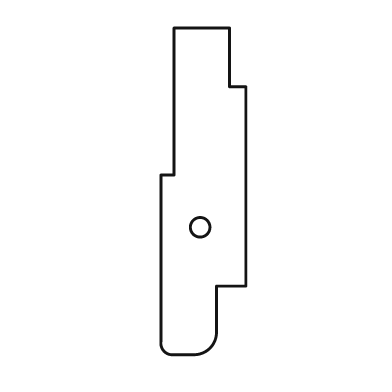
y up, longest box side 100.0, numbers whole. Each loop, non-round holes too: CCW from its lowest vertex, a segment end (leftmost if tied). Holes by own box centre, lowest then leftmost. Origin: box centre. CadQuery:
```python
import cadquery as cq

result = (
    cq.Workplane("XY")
    .moveTo(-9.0, -50.0)
    .lineTo(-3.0, -50.0)
    .threePointArc((2.0, -48.0), (4.0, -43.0))
    .lineTo(4.0, -29.0)
    .lineTo(13.0, -29.0)
    .lineTo(13.0, 32.0)
    .lineTo(8.0, 32.0)
    .lineTo(8.0, 50.0)
    .lineTo(-9.0, 50.0)
    .lineTo(-9.0, 5.0)
    .lineTo(-13.0, 5.0)
    .lineTo(-13.0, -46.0)
    .threePointArc((-12.0, -49.0), (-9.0, -50.0))
    .close()
    .moveTo(-1.0, -11.0)
    .circle(3.0)
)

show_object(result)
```